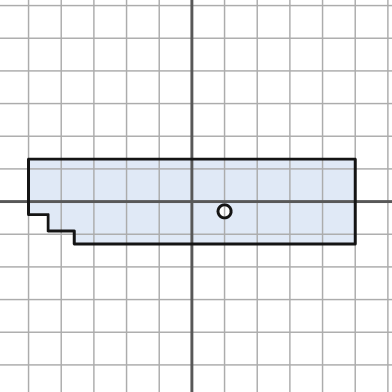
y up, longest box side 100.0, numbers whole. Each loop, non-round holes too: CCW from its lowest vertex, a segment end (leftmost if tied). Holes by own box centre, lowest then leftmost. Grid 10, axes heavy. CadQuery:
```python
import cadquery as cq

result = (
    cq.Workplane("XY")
    .moveTo(-36.0, -13.0)
    .lineTo(50.0, -13.0)
    .lineTo(50.0, 13.0)
    .lineTo(-50.0, 13.0)
    .lineTo(-50.0, -4.0)
    .lineTo(-44.0, -4.0)
    .lineTo(-44.0, -9.0)
    .lineTo(-36.0, -9.0)
    .close()
    .moveTo(10.0, -3.0)
    .circle(2.0)
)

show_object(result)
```